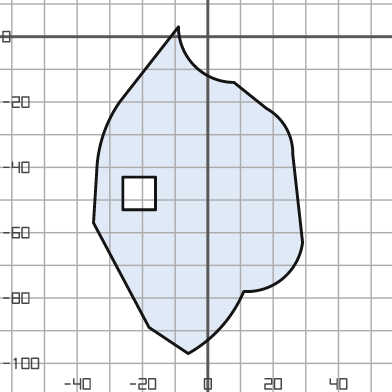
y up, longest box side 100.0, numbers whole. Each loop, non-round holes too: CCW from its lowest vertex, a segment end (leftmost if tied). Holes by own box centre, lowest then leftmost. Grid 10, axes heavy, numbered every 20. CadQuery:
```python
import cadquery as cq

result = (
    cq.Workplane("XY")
    .moveTo(-6.0, -97.0)
    .threePointArc((4.0, -89.0), (11.0, -78.0))
    .threePointArc((23.0, -74.0), (29.0, -63.0))
    .lineTo(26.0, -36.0)
    .threePointArc((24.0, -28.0), (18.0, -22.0))
    .lineTo(8.0, -14.0)
    .threePointArc((-4.0, -9.0), (-9.0, 3.0))
    .lineTo(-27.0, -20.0)
    .threePointArc((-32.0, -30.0), (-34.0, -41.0))
    .lineTo(-35.0, -57.0)
    .lineTo(-18.0, -89.0)
    .close()
    .moveTo(-26.0, -53.0)
    .lineTo(-16.0, -53.0)
    .lineTo(-16.0, -43.0)
    .lineTo(-26.0, -43.0)
    .close()
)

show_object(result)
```